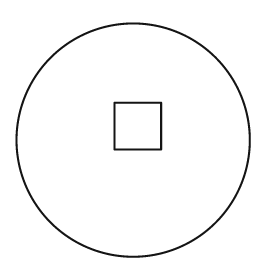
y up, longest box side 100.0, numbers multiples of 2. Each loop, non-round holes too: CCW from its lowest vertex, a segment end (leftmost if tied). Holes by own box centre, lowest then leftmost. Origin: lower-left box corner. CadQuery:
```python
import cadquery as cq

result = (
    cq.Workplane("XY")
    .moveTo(50.0, 50.0)
    .circle(50.0)
    .moveTo(42.0, 46.0)
    .lineTo(62.0, 46.0)
    .lineTo(62.0, 66.0)
    .lineTo(42.0, 66.0)
    .close()
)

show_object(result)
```